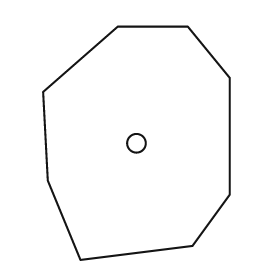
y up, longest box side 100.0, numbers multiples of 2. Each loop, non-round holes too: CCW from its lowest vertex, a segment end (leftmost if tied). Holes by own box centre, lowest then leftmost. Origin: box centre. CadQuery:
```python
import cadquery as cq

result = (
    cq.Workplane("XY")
    .moveTo(-24.0, -50.0)
    .lineTo(24.0, -44.0)
    .lineTo(40.0, -22.0)
    .lineTo(40.0, 28.0)
    .lineTo(22.0, 50.0)
    .lineTo(-8.0, 50.0)
    .lineTo(-40.0, 22.0)
    .lineTo(-38.0, -16.0)
    .close()
    .moveTo(0.0, 0.0)
    .circle(4.0)
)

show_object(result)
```